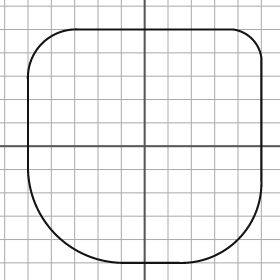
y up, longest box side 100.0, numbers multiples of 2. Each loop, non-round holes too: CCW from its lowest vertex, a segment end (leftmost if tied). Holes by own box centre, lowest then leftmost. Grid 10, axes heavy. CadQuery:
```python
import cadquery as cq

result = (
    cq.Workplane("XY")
    .moveTo(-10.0, -50.0)
    .lineTo(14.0, -50.0)
    .threePointArc((40.0, -40.0), (50.0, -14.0))
    .lineTo(50.0, 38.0)
    .threePointArc((46.0, 46.0), (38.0, 50.0))
    .lineTo(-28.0, 50.0)
    .threePointArc((-44.0, 44.0), (-50.0, 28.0))
    .lineTo(-50.0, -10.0)
    .threePointArc((-38.0, -38.0), (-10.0, -50.0))
    .close()
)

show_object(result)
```